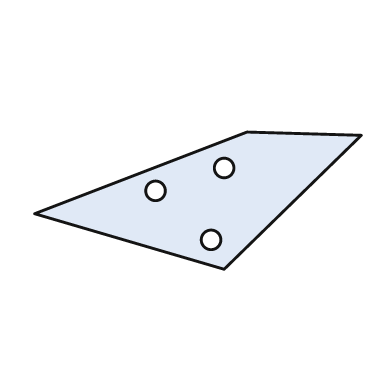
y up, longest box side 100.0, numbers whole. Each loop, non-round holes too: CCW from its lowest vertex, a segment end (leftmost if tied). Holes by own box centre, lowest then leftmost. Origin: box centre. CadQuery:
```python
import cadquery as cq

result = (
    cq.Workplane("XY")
    .moveTo(8.0, -21.0)
    .lineTo(50.0, 20.0)
    .lineTo(15.0, 21.0)
    .lineTo(-50.0, -4.0)
    .close()
    .moveTo(4.0, -12.0)
    .circle(3.0)
    .moveTo(-13.0, 3.0)
    .circle(3.0)
    .moveTo(8.0, 10.0)
    .circle(3.0)
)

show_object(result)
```